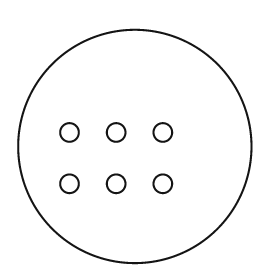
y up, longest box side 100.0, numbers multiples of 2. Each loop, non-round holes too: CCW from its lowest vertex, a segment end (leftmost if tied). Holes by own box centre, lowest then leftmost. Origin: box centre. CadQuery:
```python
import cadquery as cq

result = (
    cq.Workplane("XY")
    .moveTo(0.0, 0.0)
    .circle(50.0)
    .moveTo(-28.0, -16.0)
    .circle(4.0)
    .moveTo(-8.0, -16.0)
    .circle(4.0)
    .moveTo(12.0, -16.0)
    .circle(4.0)
    .moveTo(-28.0, 6.0)
    .circle(4.0)
    .moveTo(-8.0, 6.0)
    .circle(4.0)
    .moveTo(12.0, 6.0)
    .circle(4.0)
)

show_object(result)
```